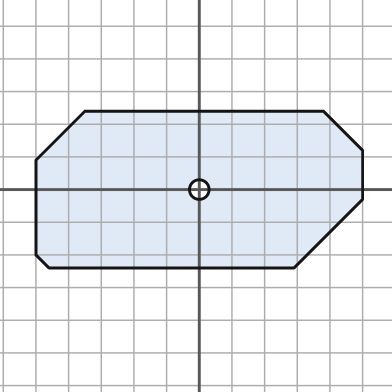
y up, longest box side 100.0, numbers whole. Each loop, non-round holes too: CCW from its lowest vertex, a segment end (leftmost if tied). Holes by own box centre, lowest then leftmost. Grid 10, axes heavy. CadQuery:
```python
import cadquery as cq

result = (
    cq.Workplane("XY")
    .moveTo(-46.0, -24.0)
    .lineTo(29.0, -24.0)
    .lineTo(50.0, -3.0)
    .lineTo(50.0, 12.0)
    .lineTo(38.0, 24.0)
    .lineTo(-35.0, 24.0)
    .lineTo(-50.0, 9.0)
    .lineTo(-50.0, -20.0)
    .close()
    .moveTo(0.0, 0.0)
    .circle(3.0)
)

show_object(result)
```